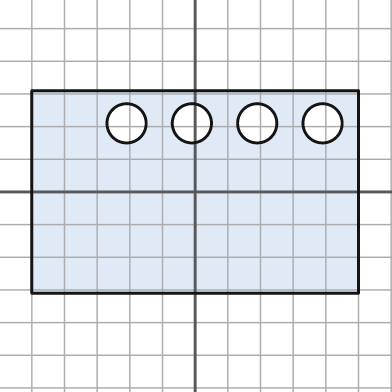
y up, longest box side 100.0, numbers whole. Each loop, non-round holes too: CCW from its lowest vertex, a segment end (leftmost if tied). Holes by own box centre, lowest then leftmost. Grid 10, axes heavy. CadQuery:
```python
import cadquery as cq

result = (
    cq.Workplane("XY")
    .moveTo(-50.0, -31.0)
    .lineTo(50.0, -31.0)
    .lineTo(50.0, 31.0)
    .lineTo(-50.0, 31.0)
    .close()
    .moveTo(-21.0, 21.0)
    .circle(6.0)
    .moveTo(-1.0, 21.0)
    .circle(6.0)
    .moveTo(19.0, 21.0)
    .circle(6.0)
    .moveTo(39.0, 21.0)
    .circle(6.0)
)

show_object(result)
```